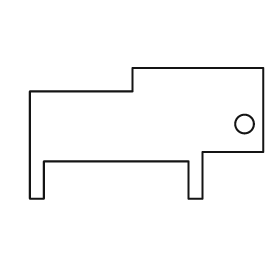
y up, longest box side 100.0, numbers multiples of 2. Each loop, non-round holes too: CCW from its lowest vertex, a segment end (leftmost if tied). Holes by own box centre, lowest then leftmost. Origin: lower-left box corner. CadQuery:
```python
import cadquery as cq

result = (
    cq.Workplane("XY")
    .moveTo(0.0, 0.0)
    .lineTo(6.0, 0.0)
    .lineTo(6.0, 16.0)
    .lineTo(68.0, 16.0)
    .lineTo(68.0, 0.0)
    .lineTo(74.0, 0.0)
    .lineTo(74.0, 20.0)
    .lineTo(100.0, 20.0)
    .lineTo(100.0, 56.0)
    .lineTo(44.0, 56.0)
    .lineTo(44.0, 46.0)
    .lineTo(0.0, 46.0)
    .close()
    .moveTo(92.0, 32.0)
    .circle(4.0)
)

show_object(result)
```